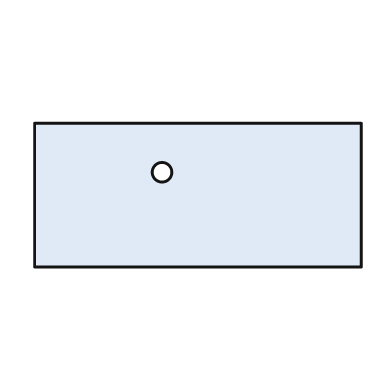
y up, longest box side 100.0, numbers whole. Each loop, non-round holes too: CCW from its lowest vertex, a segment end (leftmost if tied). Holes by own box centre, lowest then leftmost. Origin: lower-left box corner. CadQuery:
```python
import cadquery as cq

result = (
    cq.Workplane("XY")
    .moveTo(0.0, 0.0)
    .lineTo(100.0, 0.0)
    .lineTo(100.0, 44.0)
    .lineTo(0.0, 44.0)
    .close()
    .moveTo(39.0, 29.0)
    .circle(3.0)
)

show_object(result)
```